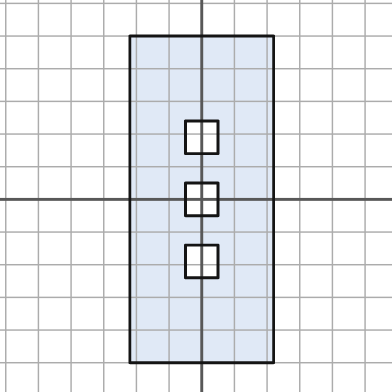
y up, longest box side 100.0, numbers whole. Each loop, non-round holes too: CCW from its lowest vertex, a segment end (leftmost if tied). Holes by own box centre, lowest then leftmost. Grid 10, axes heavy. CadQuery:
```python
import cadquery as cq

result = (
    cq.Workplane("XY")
    .moveTo(-22.0, -50.0)
    .lineTo(22.0, -50.0)
    .lineTo(22.0, 50.0)
    .lineTo(-22.0, 50.0)
    .close()
    .moveTo(-5.0, -24.0)
    .lineTo(5.0, -24.0)
    .lineTo(5.0, -14.0)
    .lineTo(-5.0, -14.0)
    .close()
    .moveTo(-5.0, -5.0)
    .lineTo(5.0, -5.0)
    .lineTo(5.0, 5.0)
    .lineTo(-5.0, 5.0)
    .close()
    .moveTo(-5.0, 14.0)
    .lineTo(5.0, 14.0)
    .lineTo(5.0, 24.0)
    .lineTo(-5.0, 24.0)
    .close()
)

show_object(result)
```